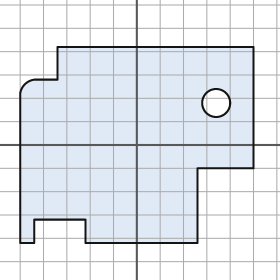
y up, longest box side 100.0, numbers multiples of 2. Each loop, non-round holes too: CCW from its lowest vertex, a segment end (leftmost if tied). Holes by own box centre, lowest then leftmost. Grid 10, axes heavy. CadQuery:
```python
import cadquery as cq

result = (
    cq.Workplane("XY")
    .moveTo(-50.0, -42.0)
    .lineTo(-44.0, -42.0)
    .lineTo(-44.0, -32.0)
    .lineTo(-22.0, -32.0)
    .lineTo(-22.0, -42.0)
    .lineTo(26.0, -42.0)
    .lineTo(26.0, -10.0)
    .lineTo(50.0, -10.0)
    .lineTo(50.0, 42.0)
    .lineTo(-34.0, 42.0)
    .lineTo(-34.0, 28.0)
    .lineTo(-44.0, 28.0)
    .threePointArc((-48.0, 26.0), (-50.0, 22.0))
    .close()
    .moveTo(34.0, 18.0)
    .circle(6.0)
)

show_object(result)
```